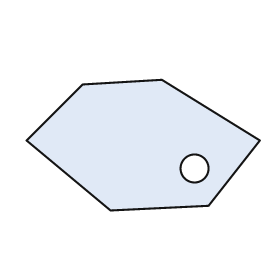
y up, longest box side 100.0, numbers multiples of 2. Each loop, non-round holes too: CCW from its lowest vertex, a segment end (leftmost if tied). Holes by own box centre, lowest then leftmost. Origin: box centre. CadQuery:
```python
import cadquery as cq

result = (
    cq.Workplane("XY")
    .moveTo(-14.0, -28.0)
    .lineTo(28.0, -26.0)
    .lineTo(50.0, 2.0)
    .lineTo(8.0, 28.0)
    .lineTo(-26.0, 26.0)
    .lineTo(-50.0, 2.0)
    .close()
    .moveTo(22.0, -10.0)
    .circle(6.0)
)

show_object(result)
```